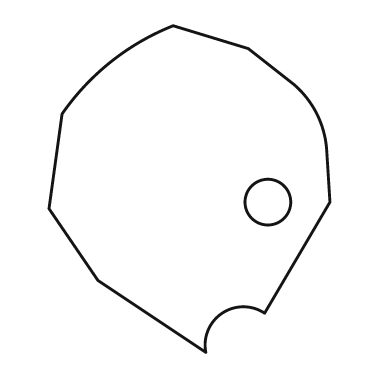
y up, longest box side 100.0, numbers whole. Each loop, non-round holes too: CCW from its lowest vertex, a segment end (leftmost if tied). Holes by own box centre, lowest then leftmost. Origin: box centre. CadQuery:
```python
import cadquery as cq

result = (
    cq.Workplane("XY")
    .moveTo(5.0, -50.0)
    .threePointArc((10.0, -38.0), (23.0, -38.0))
    .lineTo(43.0, -4.0)
    .lineTo(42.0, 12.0)
    .threePointArc((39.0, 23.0), (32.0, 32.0))
    .lineTo(18.0, 43.0)
    .lineTo(-5.0, 50.0)
    .threePointArc((-24.0, 39.0), (-39.0, 23.0))
    .lineTo(-43.0, -6.0)
    .lineTo(-28.0, -28.0)
    .close()
    .moveTo(24.0, -4.0)
    .circle(7.0)
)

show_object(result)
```